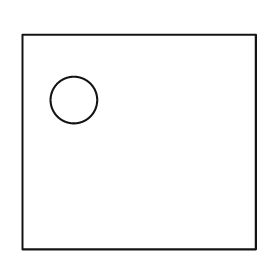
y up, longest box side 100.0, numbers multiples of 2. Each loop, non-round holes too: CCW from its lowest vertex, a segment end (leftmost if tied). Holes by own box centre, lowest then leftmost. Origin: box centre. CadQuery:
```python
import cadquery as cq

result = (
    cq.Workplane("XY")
    .moveTo(-50.0, -46.0)
    .lineTo(50.0, -46.0)
    .lineTo(50.0, 46.0)
    .lineTo(-50.0, 46.0)
    .close()
    .moveTo(-28.0, 18.0)
    .circle(10.0)
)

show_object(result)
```